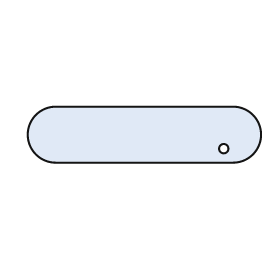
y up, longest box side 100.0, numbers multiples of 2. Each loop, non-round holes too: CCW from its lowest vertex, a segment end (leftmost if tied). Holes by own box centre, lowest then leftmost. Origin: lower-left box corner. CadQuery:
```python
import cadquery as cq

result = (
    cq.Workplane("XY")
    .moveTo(12.0, 0.0)
    .lineTo(88.0, 0.0)
    .threePointArc((100.0, 12.0), (88.0, 24.0))
    .lineTo(12.0, 24.0)
    .threePointArc((0.0, 12.0), (12.0, 0.0))
    .close()
    .moveTo(84.0, 6.0)
    .circle(2.0)
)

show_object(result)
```